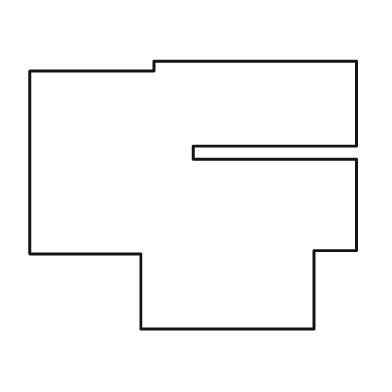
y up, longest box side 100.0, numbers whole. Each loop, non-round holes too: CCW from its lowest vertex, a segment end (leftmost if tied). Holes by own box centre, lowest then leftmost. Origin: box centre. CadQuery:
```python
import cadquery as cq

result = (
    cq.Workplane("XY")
    .moveTo(-16.0, -41.0)
    .lineTo(37.0, -41.0)
    .lineTo(37.0, -17.0)
    .lineTo(50.0, -17.0)
    .lineTo(50.0, 11.0)
    .lineTo(0.0, 11.0)
    .lineTo(0.0, 15.0)
    .lineTo(50.0, 15.0)
    .lineTo(50.0, 41.0)
    .lineTo(-12.0, 41.0)
    .lineTo(-12.0, 38.0)
    .lineTo(-50.0, 38.0)
    .lineTo(-50.0, -18.0)
    .lineTo(-16.0, -18.0)
    .close()
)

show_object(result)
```